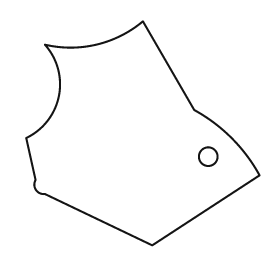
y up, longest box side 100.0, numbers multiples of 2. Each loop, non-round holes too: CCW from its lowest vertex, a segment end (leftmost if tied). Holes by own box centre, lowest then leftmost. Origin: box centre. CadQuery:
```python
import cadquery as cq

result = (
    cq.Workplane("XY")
    .moveTo(4.0, -48.0)
    .lineTo(50.0, -18.0)
    .threePointArc((38.0, -2.0), (22.0, 10.0))
    .lineTo(0.0, 48.0)
    .threePointArc((-20.0, 38.0), (-42.0, 38.0))
    .threePointArc((-36.0, 16.0), (-50.0, -2.0))
    .lineTo(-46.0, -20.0)
    .threePointArc((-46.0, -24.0), (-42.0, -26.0))
    .close()
    .moveTo(28.0, -10.0)
    .circle(4.0)
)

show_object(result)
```